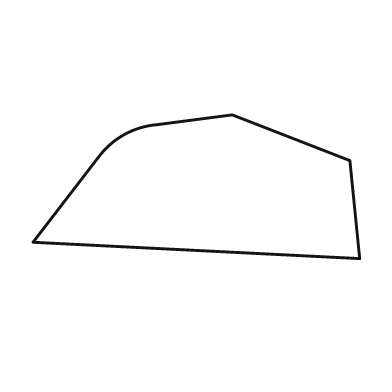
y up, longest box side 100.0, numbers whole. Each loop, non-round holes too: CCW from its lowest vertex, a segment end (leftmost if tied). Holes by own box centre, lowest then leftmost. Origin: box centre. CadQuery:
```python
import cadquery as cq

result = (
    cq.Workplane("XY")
    .moveTo(50.0, -22.0)
    .lineTo(47.0, 8.0)
    .lineTo(11.0, 22.0)
    .lineTo(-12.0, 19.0)
    .threePointArc((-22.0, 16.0), (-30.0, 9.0))
    .lineTo(-50.0, -17.0)
    .close()
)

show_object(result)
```